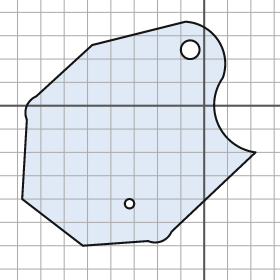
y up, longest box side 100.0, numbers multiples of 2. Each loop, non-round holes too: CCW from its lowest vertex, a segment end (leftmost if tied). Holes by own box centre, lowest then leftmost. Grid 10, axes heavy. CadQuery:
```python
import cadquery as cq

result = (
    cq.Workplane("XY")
    .moveTo(-52.0, -60.0)
    .lineTo(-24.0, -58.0)
    .threePointArc((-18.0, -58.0), (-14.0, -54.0))
    .lineTo(22.0, -20.0)
    .threePointArc((6.0, -8.0), (8.0, 12.0))
    .threePointArc((6.0, 28.0), (-8.0, 36.0))
    .lineTo(-48.0, 26.0)
    .lineTo(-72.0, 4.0)
    .threePointArc((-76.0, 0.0), (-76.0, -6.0))
    .lineTo(-78.0, -40.0)
    .close()
    .moveTo(-32.0, -42.0)
    .circle(2.0)
    .moveTo(-6.0, 24.0)
    .circle(4.0)
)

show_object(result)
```